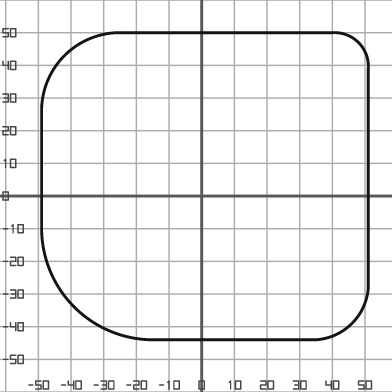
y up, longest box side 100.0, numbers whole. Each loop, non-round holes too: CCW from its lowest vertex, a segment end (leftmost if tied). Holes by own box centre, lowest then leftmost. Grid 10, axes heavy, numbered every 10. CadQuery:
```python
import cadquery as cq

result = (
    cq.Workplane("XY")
    .moveTo(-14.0, -44.0)
    .lineTo(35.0, -44.0)
    .threePointArc((46.0, -39.0), (51.0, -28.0))
    .lineTo(51.0, 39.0)
    .threePointArc((48.0, 47.0), (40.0, 50.0))
    .lineTo(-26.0, 50.0)
    .threePointArc((-42.0, 43.0), (-49.0, 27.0))
    .lineTo(-49.0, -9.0)
    .threePointArc((-39.0, -34.0), (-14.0, -44.0))
    .close()
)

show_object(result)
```